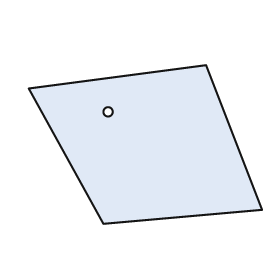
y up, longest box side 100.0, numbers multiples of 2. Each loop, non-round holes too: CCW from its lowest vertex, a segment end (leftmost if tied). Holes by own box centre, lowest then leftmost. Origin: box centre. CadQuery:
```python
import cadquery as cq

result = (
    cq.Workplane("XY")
    .moveTo(-18.0, -34.0)
    .lineTo(50.0, -28.0)
    .lineTo(26.0, 34.0)
    .lineTo(-50.0, 24.0)
    .close()
    .moveTo(-16.0, 14.0)
    .circle(2.0)
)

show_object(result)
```